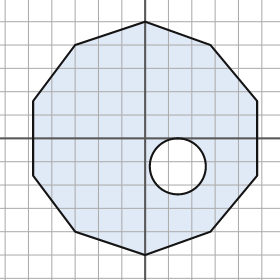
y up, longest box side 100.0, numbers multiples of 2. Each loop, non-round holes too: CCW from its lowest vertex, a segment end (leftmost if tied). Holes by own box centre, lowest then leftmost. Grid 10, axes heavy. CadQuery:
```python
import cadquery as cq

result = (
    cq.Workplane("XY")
    .moveTo(0.0, -50.0)
    .lineTo(28.0, -40.0)
    .lineTo(48.0, -16.0)
    .lineTo(48.0, 16.0)
    .lineTo(28.0, 40.0)
    .lineTo(0.0, 50.0)
    .lineTo(-30.0, 40.0)
    .lineTo(-48.0, 16.0)
    .lineTo(-48.0, -16.0)
    .lineTo(-30.0, -40.0)
    .close()
    .moveTo(14.0, -12.0)
    .circle(12.0)
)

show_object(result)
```